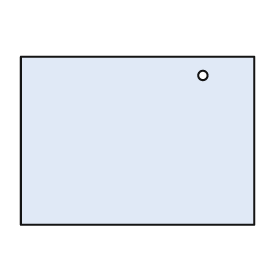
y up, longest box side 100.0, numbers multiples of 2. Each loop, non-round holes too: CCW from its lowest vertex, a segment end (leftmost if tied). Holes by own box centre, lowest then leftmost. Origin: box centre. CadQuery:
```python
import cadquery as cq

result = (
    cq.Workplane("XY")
    .moveTo(-50.0, -36.0)
    .lineTo(50.0, -36.0)
    .lineTo(50.0, 36.0)
    .lineTo(-50.0, 36.0)
    .close()
    .moveTo(28.0, 28.0)
    .circle(2.0)
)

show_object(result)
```